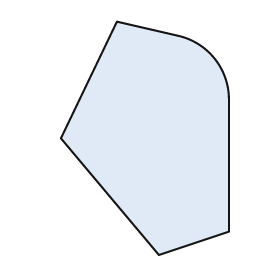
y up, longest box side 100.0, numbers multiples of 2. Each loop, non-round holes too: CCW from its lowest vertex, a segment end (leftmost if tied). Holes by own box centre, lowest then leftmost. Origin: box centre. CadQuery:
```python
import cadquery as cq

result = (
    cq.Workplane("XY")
    .moveTo(6.0, -50.0)
    .lineTo(36.0, -40.0)
    .lineTo(36.0, 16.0)
    .threePointArc((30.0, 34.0), (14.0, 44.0))
    .lineTo(-12.0, 50.0)
    .lineTo(-36.0, 0.0)
    .close()
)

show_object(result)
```